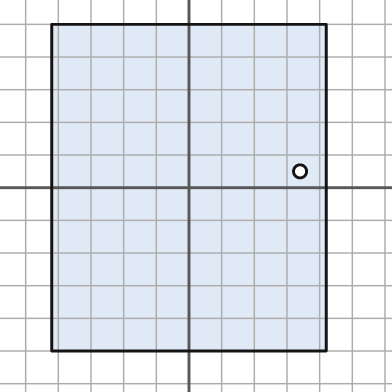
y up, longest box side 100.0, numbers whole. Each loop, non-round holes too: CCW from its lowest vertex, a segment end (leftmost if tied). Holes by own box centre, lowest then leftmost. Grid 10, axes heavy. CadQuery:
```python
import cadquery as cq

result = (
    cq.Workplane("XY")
    .moveTo(-42.0, -50.0)
    .lineTo(42.0, -50.0)
    .lineTo(42.0, 50.0)
    .lineTo(-42.0, 50.0)
    .close()
    .moveTo(34.0, 5.0)
    .circle(2.0)
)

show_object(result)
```